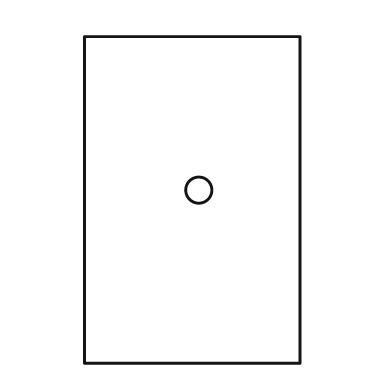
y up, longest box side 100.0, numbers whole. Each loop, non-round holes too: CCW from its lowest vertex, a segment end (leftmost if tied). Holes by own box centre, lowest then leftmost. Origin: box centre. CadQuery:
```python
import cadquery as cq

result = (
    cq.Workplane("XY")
    .moveTo(-33.0, -50.0)
    .lineTo(33.0, -50.0)
    .lineTo(33.0, 50.0)
    .lineTo(-33.0, 50.0)
    .close()
    .moveTo(2.0, 3.0)
    .circle(4.0)
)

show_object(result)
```